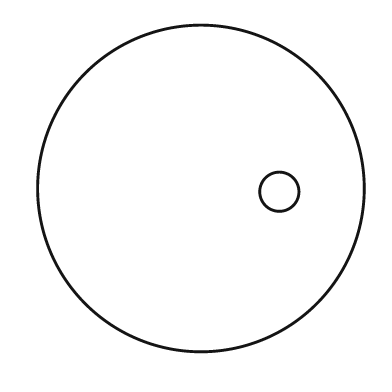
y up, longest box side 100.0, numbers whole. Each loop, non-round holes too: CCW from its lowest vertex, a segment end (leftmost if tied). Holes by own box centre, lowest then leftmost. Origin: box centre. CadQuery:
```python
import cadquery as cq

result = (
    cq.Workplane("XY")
    .moveTo(0.0, 0.0)
    .circle(50.0)
    .moveTo(24.0, -1.0)
    .circle(6.0)
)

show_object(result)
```